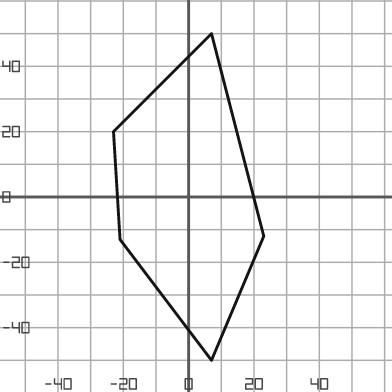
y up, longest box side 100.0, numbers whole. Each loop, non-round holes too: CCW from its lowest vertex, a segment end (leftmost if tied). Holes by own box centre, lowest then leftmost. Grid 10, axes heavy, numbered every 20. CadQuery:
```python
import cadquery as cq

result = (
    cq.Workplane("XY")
    .moveTo(7.0, -50.0)
    .lineTo(23.0, -12.0)
    .lineTo(7.0, 50.0)
    .lineTo(-23.0, 20.0)
    .lineTo(-21.0, -13.0)
    .close()
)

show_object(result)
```